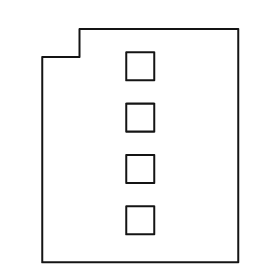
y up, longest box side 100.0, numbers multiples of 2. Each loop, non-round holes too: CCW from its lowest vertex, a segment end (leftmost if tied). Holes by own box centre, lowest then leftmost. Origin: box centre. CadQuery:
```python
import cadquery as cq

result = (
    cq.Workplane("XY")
    .moveTo(-42.0, -50.0)
    .lineTo(42.0, -50.0)
    .lineTo(42.0, 50.0)
    .lineTo(-26.0, 50.0)
    .lineTo(-26.0, 38.0)
    .lineTo(-42.0, 38.0)
    .close()
    .moveTo(-6.0, -38.0)
    .lineTo(6.0, -38.0)
    .lineTo(6.0, -26.0)
    .lineTo(-6.0, -26.0)
    .close()
    .moveTo(-6.0, -16.0)
    .lineTo(6.0, -16.0)
    .lineTo(6.0, -4.0)
    .lineTo(-6.0, -4.0)
    .close()
    .moveTo(-6.0, 6.0)
    .lineTo(6.0, 6.0)
    .lineTo(6.0, 18.0)
    .lineTo(-6.0, 18.0)
    .close()
    .moveTo(-6.0, 28.0)
    .lineTo(6.0, 28.0)
    .lineTo(6.0, 40.0)
    .lineTo(-6.0, 40.0)
    .close()
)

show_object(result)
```